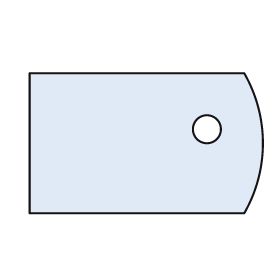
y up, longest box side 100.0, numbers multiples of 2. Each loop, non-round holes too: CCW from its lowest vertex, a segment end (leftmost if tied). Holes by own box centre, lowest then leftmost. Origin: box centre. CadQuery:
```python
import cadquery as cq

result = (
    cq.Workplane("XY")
    .moveTo(-50.0, -30.0)
    .lineTo(42.0, -30.0)
    .threePointArc((50.0, 0.0), (42.0, 30.0))
    .lineTo(-50.0, 30.0)
    .close()
    .moveTo(26.0, 6.0)
    .circle(6.0)
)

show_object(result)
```